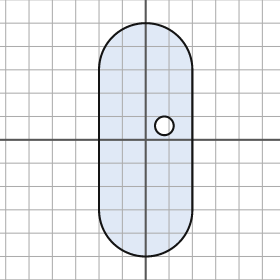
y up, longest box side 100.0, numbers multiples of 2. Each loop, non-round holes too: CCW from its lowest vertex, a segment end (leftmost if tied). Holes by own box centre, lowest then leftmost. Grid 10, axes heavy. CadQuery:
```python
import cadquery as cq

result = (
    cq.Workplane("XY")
    .moveTo(-20.0, -30.0)
    .threePointArc((0.0, -50.0), (20.0, -30.0))
    .lineTo(20.0, 30.0)
    .threePointArc((0.0, 50.0), (-20.0, 30.0))
    .close()
    .moveTo(8.0, 6.0)
    .circle(4.0)
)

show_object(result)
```